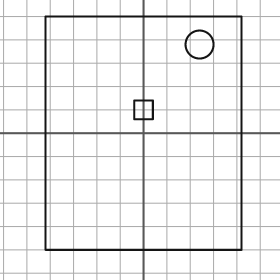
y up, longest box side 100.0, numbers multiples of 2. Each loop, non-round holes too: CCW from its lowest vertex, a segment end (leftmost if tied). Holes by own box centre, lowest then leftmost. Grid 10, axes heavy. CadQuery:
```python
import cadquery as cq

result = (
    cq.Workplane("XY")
    .moveTo(-42.0, -50.0)
    .lineTo(42.0, -50.0)
    .lineTo(42.0, 50.0)
    .lineTo(-42.0, 50.0)
    .close()
    .moveTo(-4.0, 6.0)
    .lineTo(4.0, 6.0)
    .lineTo(4.0, 14.0)
    .lineTo(-4.0, 14.0)
    .close()
    .moveTo(24.0, 38.0)
    .circle(6.0)
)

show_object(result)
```